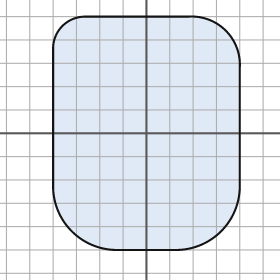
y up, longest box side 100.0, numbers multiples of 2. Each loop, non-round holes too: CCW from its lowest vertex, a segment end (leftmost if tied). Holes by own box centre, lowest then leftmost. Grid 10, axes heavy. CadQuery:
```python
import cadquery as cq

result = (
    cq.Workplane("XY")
    .moveTo(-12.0, -50.0)
    .lineTo(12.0, -50.0)
    .threePointArc((32.0, -42.0), (40.0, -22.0))
    .lineTo(40.0, 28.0)
    .threePointArc((34.0, 44.0), (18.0, 50.0))
    .lineTo(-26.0, 50.0)
    .threePointArc((-36.0, 46.0), (-40.0, 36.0))
    .lineTo(-40.0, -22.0)
    .threePointArc((-32.0, -42.0), (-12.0, -50.0))
    .close()
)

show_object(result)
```